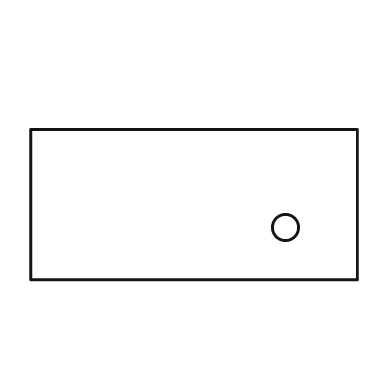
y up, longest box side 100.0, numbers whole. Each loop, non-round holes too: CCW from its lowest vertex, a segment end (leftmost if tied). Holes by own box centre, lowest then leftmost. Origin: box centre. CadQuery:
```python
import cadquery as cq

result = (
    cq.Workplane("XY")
    .moveTo(-50.0, -23.0)
    .lineTo(50.0, -23.0)
    .lineTo(50.0, 23.0)
    .lineTo(-50.0, 23.0)
    .close()
    .moveTo(28.0, -7.0)
    .circle(4.0)
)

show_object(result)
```